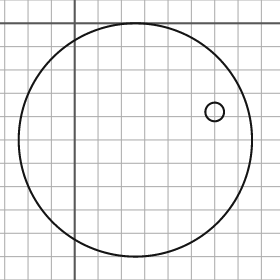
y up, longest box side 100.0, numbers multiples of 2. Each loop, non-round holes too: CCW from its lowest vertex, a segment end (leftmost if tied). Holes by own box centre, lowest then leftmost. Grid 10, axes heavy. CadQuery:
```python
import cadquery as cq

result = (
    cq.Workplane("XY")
    .moveTo(26.0, -50.0)
    .circle(50.0)
    .moveTo(60.0, -38.0)
    .circle(4.0)
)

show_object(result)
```